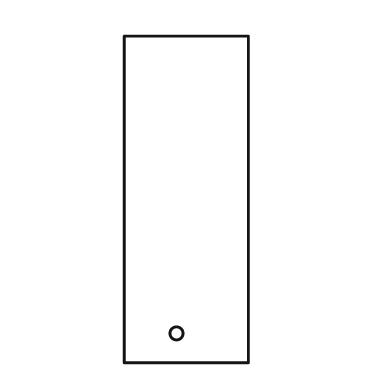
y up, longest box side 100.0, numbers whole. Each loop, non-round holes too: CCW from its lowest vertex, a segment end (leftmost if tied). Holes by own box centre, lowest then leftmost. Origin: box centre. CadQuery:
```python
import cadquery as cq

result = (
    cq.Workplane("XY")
    .moveTo(-19.0, -50.0)
    .lineTo(19.0, -50.0)
    .lineTo(19.0, 50.0)
    .lineTo(-19.0, 50.0)
    .close()
    .moveTo(-3.0, -41.0)
    .circle(2.0)
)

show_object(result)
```